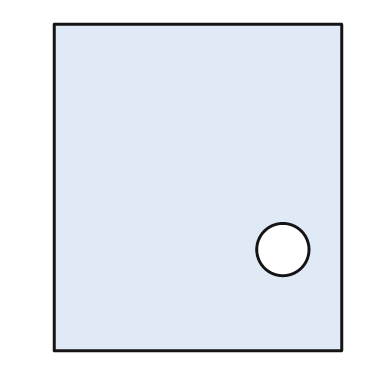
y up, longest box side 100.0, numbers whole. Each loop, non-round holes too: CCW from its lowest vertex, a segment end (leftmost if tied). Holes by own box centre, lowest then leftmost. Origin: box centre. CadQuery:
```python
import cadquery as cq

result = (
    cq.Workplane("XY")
    .moveTo(-44.0, -50.0)
    .lineTo(44.0, -50.0)
    .lineTo(44.0, 50.0)
    .lineTo(-44.0, 50.0)
    .close()
    .moveTo(26.0, -19.0)
    .circle(8.0)
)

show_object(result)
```